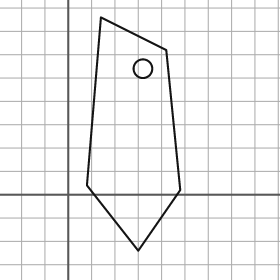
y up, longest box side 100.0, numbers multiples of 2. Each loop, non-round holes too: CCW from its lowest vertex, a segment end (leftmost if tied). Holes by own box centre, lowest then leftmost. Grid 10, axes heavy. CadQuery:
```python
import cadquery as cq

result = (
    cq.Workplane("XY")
    .moveTo(30.0, -24.0)
    .lineTo(48.0, 2.0)
    .lineTo(42.0, 62.0)
    .lineTo(14.0, 76.0)
    .lineTo(8.0, 4.0)
    .close()
    .moveTo(32.0, 54.0)
    .circle(4.0)
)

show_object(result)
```